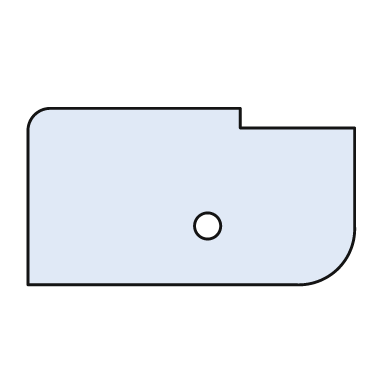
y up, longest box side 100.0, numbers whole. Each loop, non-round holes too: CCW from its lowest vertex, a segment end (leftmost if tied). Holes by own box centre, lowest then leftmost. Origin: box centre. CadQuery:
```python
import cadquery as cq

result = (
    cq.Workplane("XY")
    .moveTo(-50.0, -27.0)
    .lineTo(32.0, -27.0)
    .threePointArc((45.0, -22.0), (50.0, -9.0))
    .lineTo(50.0, 21.0)
    .lineTo(15.0, 21.0)
    .lineTo(15.0, 27.0)
    .lineTo(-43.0, 27.0)
    .threePointArc((-48.0, 25.0), (-50.0, 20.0))
    .close()
    .moveTo(5.0, -9.0)
    .circle(4.0)
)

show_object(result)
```